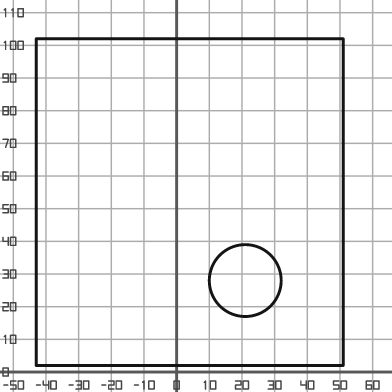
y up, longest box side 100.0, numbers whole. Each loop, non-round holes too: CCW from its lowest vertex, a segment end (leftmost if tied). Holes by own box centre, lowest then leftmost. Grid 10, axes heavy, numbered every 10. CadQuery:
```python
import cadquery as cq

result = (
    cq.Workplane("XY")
    .moveTo(-43.0, 2.0)
    .lineTo(51.0, 2.0)
    .lineTo(51.0, 102.0)
    .lineTo(-43.0, 102.0)
    .close()
    .moveTo(21.0, 28.0)
    .circle(11.0)
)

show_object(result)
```